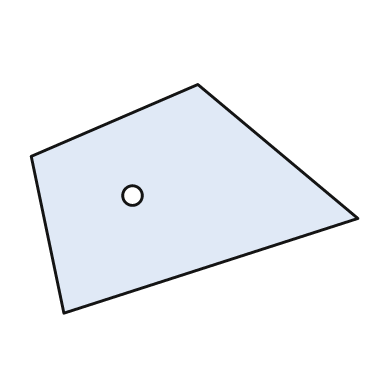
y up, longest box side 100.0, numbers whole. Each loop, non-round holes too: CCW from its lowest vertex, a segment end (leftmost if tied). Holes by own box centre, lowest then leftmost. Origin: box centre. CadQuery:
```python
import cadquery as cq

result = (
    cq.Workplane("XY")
    .moveTo(-40.0, -35.0)
    .lineTo(50.0, -6.0)
    .lineTo(1.0, 35.0)
    .lineTo(-50.0, 13.0)
    .close()
    .moveTo(-19.0, 1.0)
    .circle(3.0)
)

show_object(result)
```